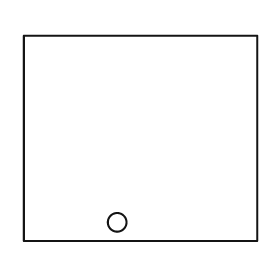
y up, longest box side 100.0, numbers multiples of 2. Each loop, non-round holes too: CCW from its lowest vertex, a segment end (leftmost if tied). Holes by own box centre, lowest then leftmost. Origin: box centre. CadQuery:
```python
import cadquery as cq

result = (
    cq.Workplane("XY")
    .moveTo(-50.0, -44.0)
    .lineTo(50.0, -44.0)
    .lineTo(50.0, 44.0)
    .lineTo(-50.0, 44.0)
    .close()
    .moveTo(-10.0, -36.0)
    .circle(4.0)
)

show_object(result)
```